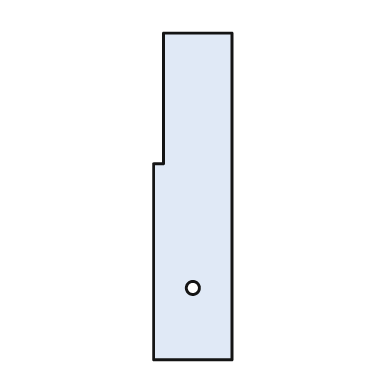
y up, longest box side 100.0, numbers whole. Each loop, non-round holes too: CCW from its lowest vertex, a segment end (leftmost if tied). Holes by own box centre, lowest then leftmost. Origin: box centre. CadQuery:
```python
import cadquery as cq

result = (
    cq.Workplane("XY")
    .moveTo(-12.0, -50.0)
    .lineTo(12.0, -50.0)
    .lineTo(12.0, 50.0)
    .lineTo(-9.0, 50.0)
    .lineTo(-9.0, 10.0)
    .lineTo(-12.0, 10.0)
    .close()
    .moveTo(0.0, -28.0)
    .circle(2.0)
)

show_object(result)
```